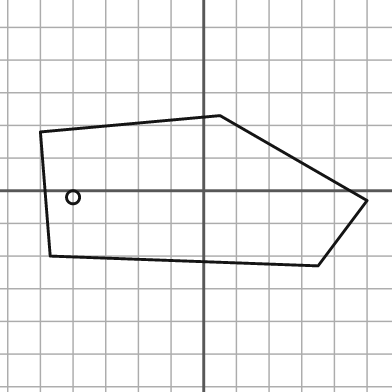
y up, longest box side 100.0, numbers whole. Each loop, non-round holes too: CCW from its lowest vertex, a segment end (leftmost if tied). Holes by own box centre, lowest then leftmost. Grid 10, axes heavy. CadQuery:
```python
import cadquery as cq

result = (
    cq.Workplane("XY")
    .moveTo(35.0, -23.0)
    .lineTo(50.0, -3.0)
    .lineTo(5.0, 23.0)
    .lineTo(-50.0, 18.0)
    .lineTo(-47.0, -20.0)
    .close()
    .moveTo(-40.0, -2.0)
    .circle(2.0)
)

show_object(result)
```